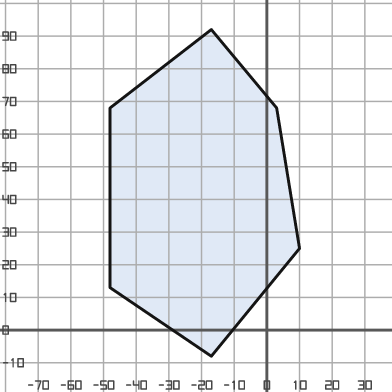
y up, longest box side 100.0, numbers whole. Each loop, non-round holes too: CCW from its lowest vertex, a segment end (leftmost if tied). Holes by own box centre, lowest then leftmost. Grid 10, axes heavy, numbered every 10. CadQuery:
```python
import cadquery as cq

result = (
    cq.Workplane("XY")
    .moveTo(-17.0, -8.0)
    .lineTo(10.0, 25.0)
    .lineTo(3.0, 68.0)
    .lineTo(-17.0, 92.0)
    .lineTo(-48.0, 68.0)
    .lineTo(-48.0, 13.0)
    .close()
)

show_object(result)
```